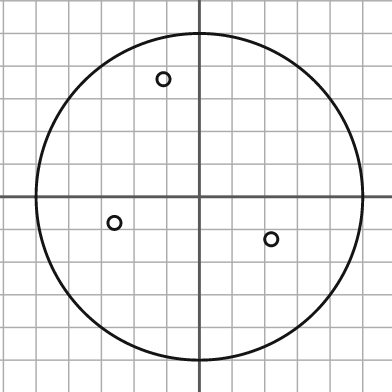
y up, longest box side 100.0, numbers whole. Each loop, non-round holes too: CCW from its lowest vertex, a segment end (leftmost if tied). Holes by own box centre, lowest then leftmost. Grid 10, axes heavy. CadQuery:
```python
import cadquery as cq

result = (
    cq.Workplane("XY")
    .moveTo(0.0, 0.0)
    .circle(50.0)
    .moveTo(22.0, -13.0)
    .circle(2.0)
    .moveTo(-26.0, -8.0)
    .circle(2.0)
    .moveTo(-11.0, 36.0)
    .circle(2.0)
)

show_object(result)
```